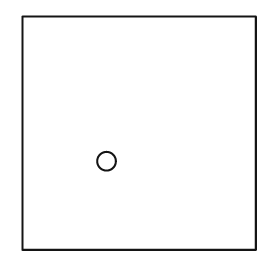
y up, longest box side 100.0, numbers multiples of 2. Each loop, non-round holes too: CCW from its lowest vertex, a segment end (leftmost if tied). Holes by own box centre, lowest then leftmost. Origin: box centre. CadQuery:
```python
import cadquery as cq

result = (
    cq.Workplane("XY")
    .moveTo(-50.0, -50.0)
    .lineTo(50.0, -50.0)
    .lineTo(50.0, 50.0)
    .lineTo(-50.0, 50.0)
    .close()
    .moveTo(-14.0, -12.0)
    .circle(4.0)
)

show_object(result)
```